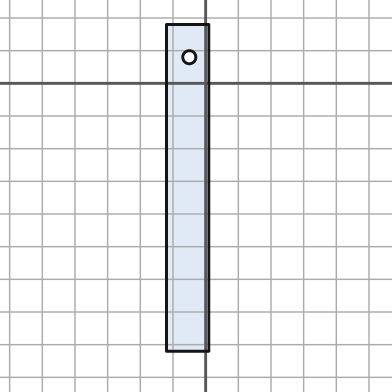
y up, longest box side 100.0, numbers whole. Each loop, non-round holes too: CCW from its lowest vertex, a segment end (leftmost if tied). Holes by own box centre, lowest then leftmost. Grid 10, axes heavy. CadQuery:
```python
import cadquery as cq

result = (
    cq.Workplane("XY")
    .moveTo(-12.0, -82.0)
    .lineTo(1.0, -82.0)
    .lineTo(1.0, 18.0)
    .lineTo(-12.0, 18.0)
    .close()
    .moveTo(-5.0, 8.0)
    .circle(2.0)
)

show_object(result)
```